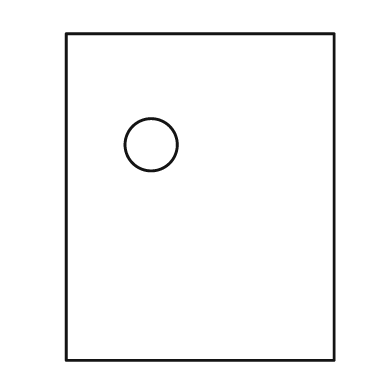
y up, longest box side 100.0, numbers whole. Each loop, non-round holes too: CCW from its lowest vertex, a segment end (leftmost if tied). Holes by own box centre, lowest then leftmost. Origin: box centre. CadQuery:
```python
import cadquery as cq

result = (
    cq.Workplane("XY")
    .moveTo(-41.0, -50.0)
    .lineTo(41.0, -50.0)
    .lineTo(41.0, 50.0)
    .lineTo(-41.0, 50.0)
    .close()
    .moveTo(-15.0, 16.0)
    .circle(8.0)
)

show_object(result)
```